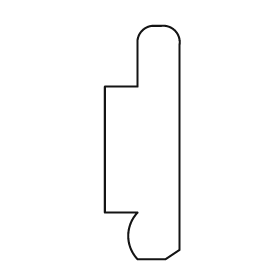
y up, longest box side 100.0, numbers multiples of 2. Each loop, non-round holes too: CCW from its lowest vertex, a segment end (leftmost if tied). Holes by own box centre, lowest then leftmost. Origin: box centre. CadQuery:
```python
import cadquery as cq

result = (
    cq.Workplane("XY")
    .moveTo(-2.0, -50.0)
    .lineTo(10.0, -50.0)
    .lineTo(16.0, -46.0)
    .lineTo(16.0, 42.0)
    .threePointArc((14.0, 48.0), (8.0, 50.0))
    .lineTo(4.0, 50.0)
    .threePointArc((0.0, 48.0), (-2.0, 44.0))
    .lineTo(-2.0, 24.0)
    .lineTo(-16.0, 24.0)
    .lineTo(-16.0, -30.0)
    .lineTo(-2.0, -30.0)
    .threePointArc((-6.0, -40.0), (-2.0, -50.0))
    .close()
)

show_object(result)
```